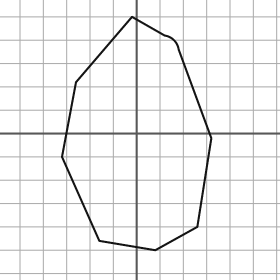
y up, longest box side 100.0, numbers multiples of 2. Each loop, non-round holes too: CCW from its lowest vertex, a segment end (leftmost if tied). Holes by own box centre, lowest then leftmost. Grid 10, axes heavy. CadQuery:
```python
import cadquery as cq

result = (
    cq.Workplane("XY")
    .moveTo(8.0, -50.0)
    .lineTo(26.0, -40.0)
    .lineTo(32.0, -2.0)
    .lineTo(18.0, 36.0)
    .threePointArc((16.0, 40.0), (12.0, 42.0))
    .lineTo(-2.0, 50.0)
    .lineTo(-26.0, 22.0)
    .lineTo(-32.0, -10.0)
    .lineTo(-16.0, -46.0)
    .close()
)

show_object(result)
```